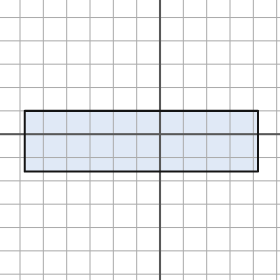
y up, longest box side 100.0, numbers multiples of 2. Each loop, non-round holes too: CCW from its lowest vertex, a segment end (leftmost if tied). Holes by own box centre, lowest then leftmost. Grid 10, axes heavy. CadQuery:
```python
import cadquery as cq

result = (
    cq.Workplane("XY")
    .moveTo(-58.0, -16.0)
    .lineTo(42.0, -16.0)
    .lineTo(42.0, 10.0)
    .lineTo(-58.0, 10.0)
    .close()
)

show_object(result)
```